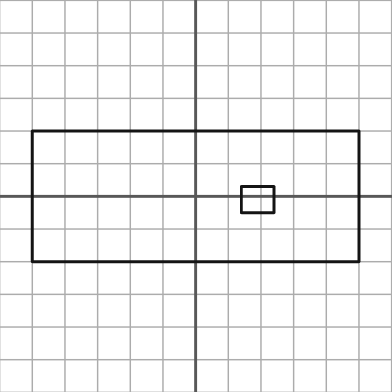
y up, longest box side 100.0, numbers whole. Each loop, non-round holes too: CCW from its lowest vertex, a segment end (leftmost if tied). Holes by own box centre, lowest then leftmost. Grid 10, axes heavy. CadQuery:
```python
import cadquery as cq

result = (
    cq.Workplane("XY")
    .moveTo(-50.0, -20.0)
    .lineTo(50.0, -20.0)
    .lineTo(50.0, 20.0)
    .lineTo(-50.0, 20.0)
    .close()
    .moveTo(14.0, -5.0)
    .lineTo(24.0, -5.0)
    .lineTo(24.0, 3.0)
    .lineTo(14.0, 3.0)
    .close()
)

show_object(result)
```